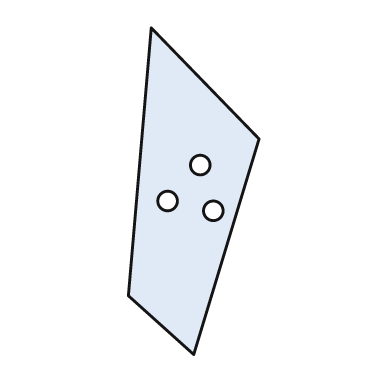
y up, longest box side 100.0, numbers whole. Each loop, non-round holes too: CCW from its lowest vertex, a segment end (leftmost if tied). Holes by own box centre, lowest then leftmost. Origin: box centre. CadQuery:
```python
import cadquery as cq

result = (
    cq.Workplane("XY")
    .moveTo(0.0, -50.0)
    .lineTo(20.0, 16.0)
    .lineTo(-13.0, 50.0)
    .lineTo(-20.0, -32.0)
    .close()
    .moveTo(6.0, -6.0)
    .circle(3.0)
    .moveTo(-8.0, -3.0)
    .circle(3.0)
    .moveTo(2.0, 8.0)
    .circle(3.0)
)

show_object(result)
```